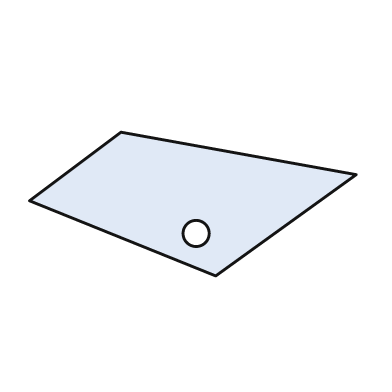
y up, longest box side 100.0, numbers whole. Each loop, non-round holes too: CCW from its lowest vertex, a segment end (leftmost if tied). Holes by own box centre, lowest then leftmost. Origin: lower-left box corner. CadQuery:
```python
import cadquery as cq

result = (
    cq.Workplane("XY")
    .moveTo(57.0, 0.0)
    .lineTo(100.0, 31.0)
    .lineTo(28.0, 44.0)
    .lineTo(0.0, 23.0)
    .close()
    .moveTo(51.0, 13.0)
    .circle(4.0)
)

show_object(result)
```